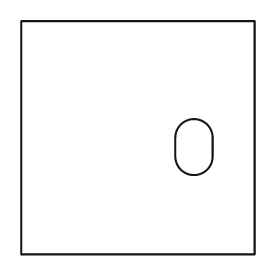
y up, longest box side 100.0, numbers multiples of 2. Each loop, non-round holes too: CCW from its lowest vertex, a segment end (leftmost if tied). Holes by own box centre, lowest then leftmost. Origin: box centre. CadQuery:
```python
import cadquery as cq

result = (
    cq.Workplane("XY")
    .moveTo(-50.0, -50.0)
    .lineTo(50.0, -50.0)
    .lineTo(50.0, 50.0)
    .lineTo(-50.0, 50.0)
    .close()
    .moveTo(16.0, -8.0)
    .threePointArc((24.0, -16.0), (32.0, -8.0))
    .lineTo(32.0, 0.0)
    .threePointArc((24.0, 8.0), (16.0, 0.0))
    .close()
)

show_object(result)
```